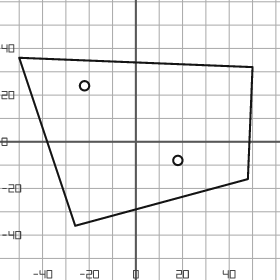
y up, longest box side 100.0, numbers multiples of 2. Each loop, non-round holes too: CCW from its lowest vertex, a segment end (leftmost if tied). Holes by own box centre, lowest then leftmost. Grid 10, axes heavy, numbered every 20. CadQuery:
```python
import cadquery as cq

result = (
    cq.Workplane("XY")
    .moveTo(-26.0, -36.0)
    .lineTo(48.0, -16.0)
    .lineTo(50.0, 32.0)
    .lineTo(-50.0, 36.0)
    .close()
    .moveTo(18.0, -8.0)
    .circle(2.0)
    .moveTo(-22.0, 24.0)
    .circle(2.0)
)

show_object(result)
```